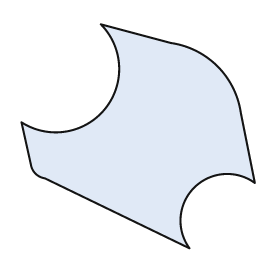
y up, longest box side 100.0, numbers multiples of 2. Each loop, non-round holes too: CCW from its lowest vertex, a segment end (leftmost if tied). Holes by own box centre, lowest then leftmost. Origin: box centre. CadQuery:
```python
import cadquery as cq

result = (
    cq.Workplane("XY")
    .moveTo(22.0, -48.0)
    .threePointArc((24.0, -22.0), (50.0, -20.0))
    .lineTo(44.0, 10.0)
    .threePointArc((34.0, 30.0), (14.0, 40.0))
    .lineTo(-16.0, 48.0)
    .threePointArc((-14.0, 12.0), (-50.0, 6.0))
    .lineTo(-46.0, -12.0)
    .threePointArc((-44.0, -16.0), (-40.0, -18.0))
    .close()
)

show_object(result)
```